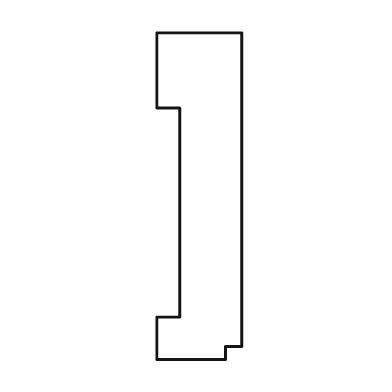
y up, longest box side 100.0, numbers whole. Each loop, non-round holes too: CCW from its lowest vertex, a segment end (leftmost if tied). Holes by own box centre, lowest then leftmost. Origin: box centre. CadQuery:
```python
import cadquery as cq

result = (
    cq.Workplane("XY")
    .moveTo(-13.0, -50.0)
    .lineTo(8.0, -50.0)
    .lineTo(8.0, -46.0)
    .lineTo(13.0, -46.0)
    .lineTo(13.0, 50.0)
    .lineTo(-13.0, 50.0)
    .lineTo(-13.0, 27.0)
    .lineTo(-6.0, 27.0)
    .lineTo(-6.0, -37.0)
    .lineTo(-13.0, -37.0)
    .close()
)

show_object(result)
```